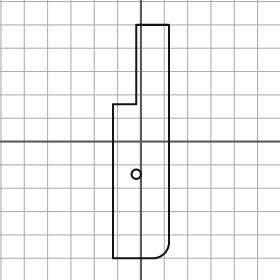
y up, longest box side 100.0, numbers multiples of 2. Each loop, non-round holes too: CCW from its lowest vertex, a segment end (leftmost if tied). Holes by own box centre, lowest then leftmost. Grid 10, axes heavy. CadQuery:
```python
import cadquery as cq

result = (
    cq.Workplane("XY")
    .moveTo(-12.0, -50.0)
    .lineTo(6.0, -50.0)
    .threePointArc((10.0, -48.0), (12.0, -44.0))
    .lineTo(12.0, 50.0)
    .lineTo(-2.0, 50.0)
    .lineTo(-2.0, 16.0)
    .lineTo(-12.0, 16.0)
    .close()
    .moveTo(-2.0, -14.0)
    .circle(2.0)
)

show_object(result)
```